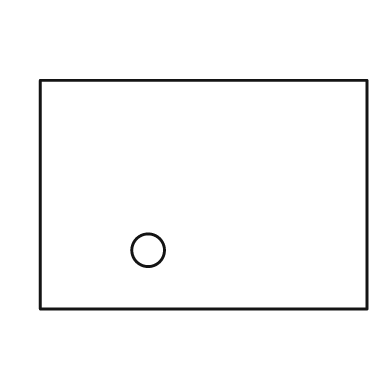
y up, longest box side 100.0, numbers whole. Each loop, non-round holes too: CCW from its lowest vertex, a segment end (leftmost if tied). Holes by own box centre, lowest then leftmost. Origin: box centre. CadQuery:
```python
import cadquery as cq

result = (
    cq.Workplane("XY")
    .moveTo(-50.0, -35.0)
    .lineTo(50.0, -35.0)
    .lineTo(50.0, 35.0)
    .lineTo(-50.0, 35.0)
    .close()
    .moveTo(-17.0, -17.0)
    .circle(5.0)
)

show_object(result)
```